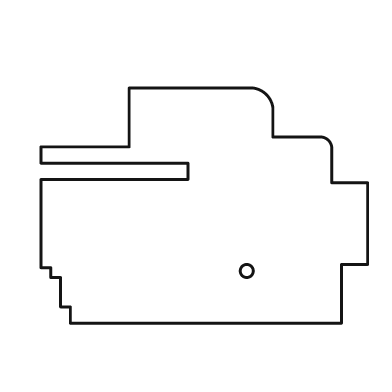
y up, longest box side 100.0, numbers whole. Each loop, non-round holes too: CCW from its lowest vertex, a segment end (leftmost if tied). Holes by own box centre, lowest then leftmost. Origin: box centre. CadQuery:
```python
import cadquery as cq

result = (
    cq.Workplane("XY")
    .moveTo(-41.0, -36.0)
    .lineTo(42.0, -36.0)
    .lineTo(42.0, -18.0)
    .lineTo(50.0, -18.0)
    .lineTo(50.0, 7.0)
    .lineTo(39.0, 7.0)
    .lineTo(39.0, 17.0)
    .threePointArc((38.0, 20.0), (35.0, 21.0))
    .lineTo(21.0, 21.0)
    .lineTo(21.0, 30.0)
    .threePointArc((19.0, 34.0), (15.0, 36.0))
    .lineTo(-23.0, 36.0)
    .lineTo(-23.0, 18.0)
    .lineTo(-50.0, 18.0)
    .lineTo(-50.0, 13.0)
    .lineTo(-5.0, 13.0)
    .lineTo(-5.0, 8.0)
    .lineTo(-50.0, 8.0)
    .lineTo(-50.0, -19.0)
    .lineTo(-47.0, -19.0)
    .lineTo(-47.0, -22.0)
    .lineTo(-44.0, -22.0)
    .lineTo(-44.0, -31.0)
    .lineTo(-41.0, -31.0)
    .close()
    .moveTo(13.0, -20.0)
    .circle(2.0)
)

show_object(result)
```